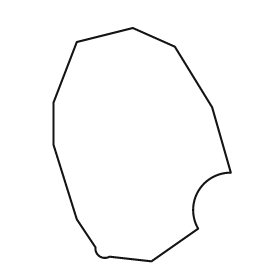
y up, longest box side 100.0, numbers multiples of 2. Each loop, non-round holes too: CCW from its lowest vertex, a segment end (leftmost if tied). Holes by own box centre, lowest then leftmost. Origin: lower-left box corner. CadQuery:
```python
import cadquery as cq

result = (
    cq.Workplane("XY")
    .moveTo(42.0, 0.0)
    .lineTo(62.0, 14.0)
    .threePointArc((62.0, 30.0), (76.0, 38.0))
    .lineTo(68.0, 66.0)
    .lineTo(52.0, 92.0)
    .lineTo(34.0, 100.0)
    .lineTo(10.0, 94.0)
    .lineTo(0.0, 68.0)
    .lineTo(0.0, 50.0)
    .lineTo(10.0, 18.0)
    .lineTo(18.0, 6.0)
    .threePointArc((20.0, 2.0), (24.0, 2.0))
    .close()
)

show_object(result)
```